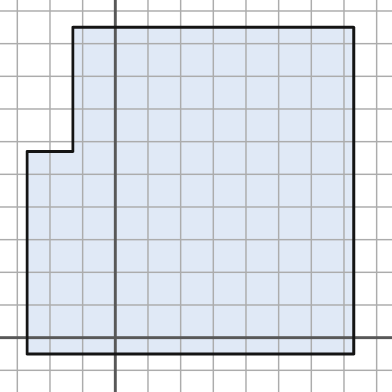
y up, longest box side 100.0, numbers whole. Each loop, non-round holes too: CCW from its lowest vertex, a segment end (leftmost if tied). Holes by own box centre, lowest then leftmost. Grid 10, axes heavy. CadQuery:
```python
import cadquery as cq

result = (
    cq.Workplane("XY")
    .moveTo(-27.0, -5.0)
    .lineTo(73.0, -5.0)
    .lineTo(73.0, 95.0)
    .lineTo(-13.0, 95.0)
    .lineTo(-13.0, 57.0)
    .lineTo(-27.0, 57.0)
    .close()
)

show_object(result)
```